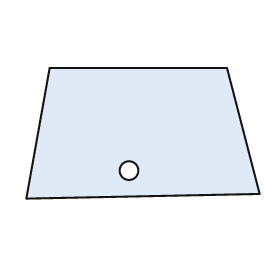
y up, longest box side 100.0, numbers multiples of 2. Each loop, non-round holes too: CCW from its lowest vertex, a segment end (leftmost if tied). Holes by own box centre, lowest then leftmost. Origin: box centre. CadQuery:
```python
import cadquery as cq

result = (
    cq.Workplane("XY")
    .moveTo(-50.0, -28.0)
    .lineTo(50.0, -26.0)
    .lineTo(36.0, 28.0)
    .lineTo(-40.0, 28.0)
    .close()
    .moveTo(-6.0, -16.0)
    .circle(4.0)
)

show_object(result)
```